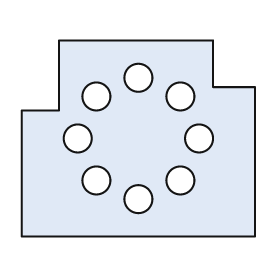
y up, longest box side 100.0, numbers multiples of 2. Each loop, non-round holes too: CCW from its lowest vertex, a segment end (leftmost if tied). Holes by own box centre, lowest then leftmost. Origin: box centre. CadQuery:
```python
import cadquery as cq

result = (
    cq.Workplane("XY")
    .moveTo(-50.0, -42.0)
    .lineTo(50.0, -42.0)
    .lineTo(50.0, 22.0)
    .lineTo(32.0, 22.0)
    .lineTo(32.0, 42.0)
    .lineTo(-34.0, 42.0)
    .lineTo(-34.0, 12.0)
    .lineTo(-50.0, 12.0)
    .close()
    .moveTo(0.0, -26.0)
    .circle(6.0)
    .moveTo(-18.0, -18.0)
    .circle(6.0)
    .moveTo(18.0, -18.0)
    .circle(6.0)
    .moveTo(-26.0, 0.0)
    .circle(6.0)
    .moveTo(26.0, 0.0)
    .circle(6.0)
    .moveTo(-18.0, 18.0)
    .circle(6.0)
    .moveTo(18.0, 18.0)
    .circle(6.0)
    .moveTo(0.0, 26.0)
    .circle(6.0)
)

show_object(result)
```